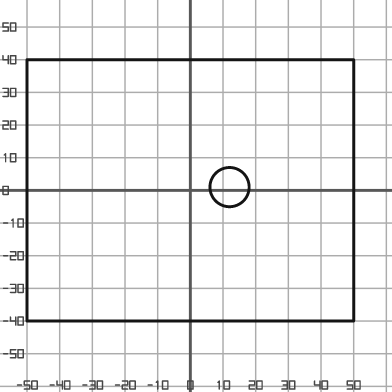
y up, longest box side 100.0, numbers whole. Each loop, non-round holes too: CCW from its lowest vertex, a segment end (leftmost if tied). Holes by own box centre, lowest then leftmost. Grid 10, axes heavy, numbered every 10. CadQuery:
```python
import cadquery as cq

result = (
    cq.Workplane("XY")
    .moveTo(-50.0, -40.0)
    .lineTo(50.0, -40.0)
    .lineTo(50.0, 40.0)
    .lineTo(-50.0, 40.0)
    .close()
    .moveTo(12.0, 1.0)
    .circle(6.0)
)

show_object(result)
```